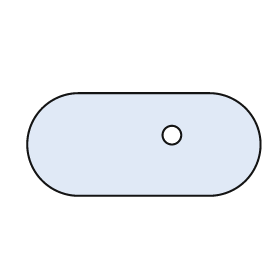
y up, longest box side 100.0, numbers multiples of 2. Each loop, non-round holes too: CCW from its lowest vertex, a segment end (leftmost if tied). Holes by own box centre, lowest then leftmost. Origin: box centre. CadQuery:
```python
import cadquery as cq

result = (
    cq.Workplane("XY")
    .moveTo(-28.0, -22.0)
    .lineTo(28.0, -22.0)
    .threePointArc((50.0, 0.0), (28.0, 22.0))
    .lineTo(-28.0, 22.0)
    .threePointArc((-50.0, 0.0), (-28.0, -22.0))
    .close()
    .moveTo(12.0, 4.0)
    .circle(4.0)
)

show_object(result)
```